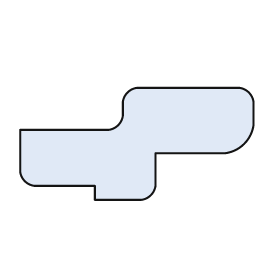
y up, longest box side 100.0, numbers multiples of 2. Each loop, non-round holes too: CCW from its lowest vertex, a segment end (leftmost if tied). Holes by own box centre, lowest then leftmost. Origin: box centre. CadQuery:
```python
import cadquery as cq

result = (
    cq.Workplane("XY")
    .moveTo(-18.0, -24.0)
    .lineTo(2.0, -24.0)
    .threePointArc((6.0, -22.0), (8.0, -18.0))
    .lineTo(8.0, -4.0)
    .lineTo(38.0, -4.0)
    .threePointArc((46.0, 0.0), (50.0, 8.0))
    .lineTo(50.0, 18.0)
    .threePointArc((48.0, 22.0), (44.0, 24.0))
    .lineTo(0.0, 24.0)
    .threePointArc((-4.0, 22.0), (-6.0, 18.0))
    .lineTo(-6.0, 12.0)
    .threePointArc((-8.0, 8.0), (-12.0, 6.0))
    .lineTo(-50.0, 6.0)
    .lineTo(-50.0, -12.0)
    .threePointArc((-48.0, -16.0), (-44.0, -18.0))
    .lineTo(-18.0, -18.0)
    .close()
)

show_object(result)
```